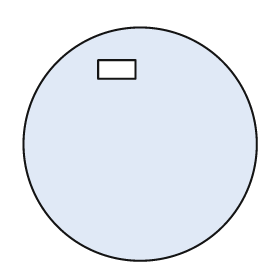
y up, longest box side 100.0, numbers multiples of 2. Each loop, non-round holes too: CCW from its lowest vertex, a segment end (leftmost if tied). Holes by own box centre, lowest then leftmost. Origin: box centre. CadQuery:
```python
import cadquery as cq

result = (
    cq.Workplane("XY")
    .moveTo(0.0, 0.0)
    .circle(50.0)
    .moveTo(-18.0, 28.0)
    .lineTo(-2.0, 28.0)
    .lineTo(-2.0, 36.0)
    .lineTo(-18.0, 36.0)
    .close()
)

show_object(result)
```